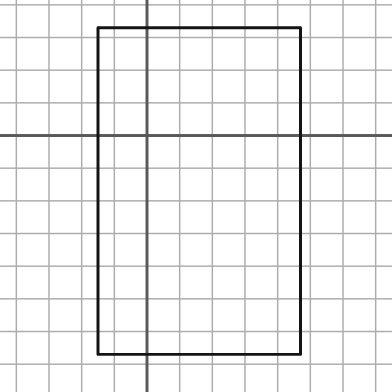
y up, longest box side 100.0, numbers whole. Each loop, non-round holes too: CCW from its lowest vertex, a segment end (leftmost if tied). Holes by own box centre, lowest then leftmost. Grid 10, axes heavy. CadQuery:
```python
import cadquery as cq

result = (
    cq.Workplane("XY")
    .moveTo(-15.0, -67.0)
    .lineTo(47.0, -67.0)
    .lineTo(47.0, 33.0)
    .lineTo(-15.0, 33.0)
    .close()
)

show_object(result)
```